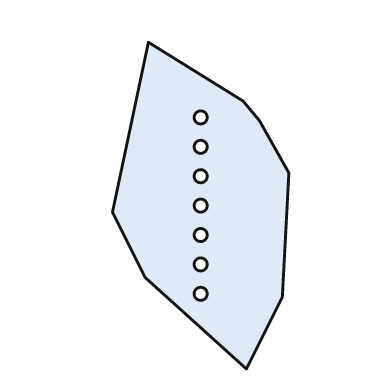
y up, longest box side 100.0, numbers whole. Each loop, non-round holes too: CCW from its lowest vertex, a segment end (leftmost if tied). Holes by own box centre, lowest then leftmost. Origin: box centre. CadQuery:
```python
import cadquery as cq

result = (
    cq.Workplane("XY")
    .moveTo(14.0, -50.0)
    .lineTo(25.0, -28.0)
    .lineTo(27.0, 10.0)
    .lineTo(18.0, 26.0)
    .lineTo(13.0, 32.0)
    .lineTo(-16.0, 50.0)
    .lineTo(-27.0, -2.0)
    .lineTo(-17.0, -22.0)
    .close()
    .moveTo(0.0, -27.0)
    .circle(2.0)
    .moveTo(0.0, -18.0)
    .circle(2.0)
    .moveTo(0.0, -9.0)
    .circle(2.0)
    .moveTo(0.0, 0.0)
    .circle(2.0)
    .moveTo(0.0, 9.0)
    .circle(2.0)
    .moveTo(0.0, 18.0)
    .circle(2.0)
    .moveTo(0.0, 27.0)
    .circle(2.0)
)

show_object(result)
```